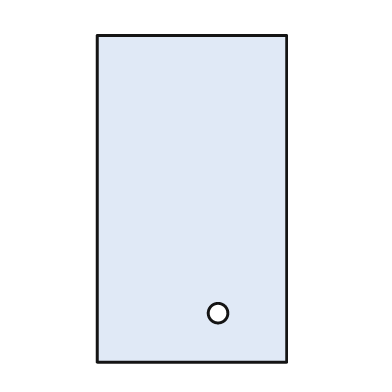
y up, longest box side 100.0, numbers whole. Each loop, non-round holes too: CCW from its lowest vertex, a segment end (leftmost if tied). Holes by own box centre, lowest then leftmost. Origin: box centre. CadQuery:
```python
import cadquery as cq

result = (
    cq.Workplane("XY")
    .moveTo(-29.0, -50.0)
    .lineTo(29.0, -50.0)
    .lineTo(29.0, 50.0)
    .lineTo(-29.0, 50.0)
    .close()
    .moveTo(8.0, -35.0)
    .circle(3.0)
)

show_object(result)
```